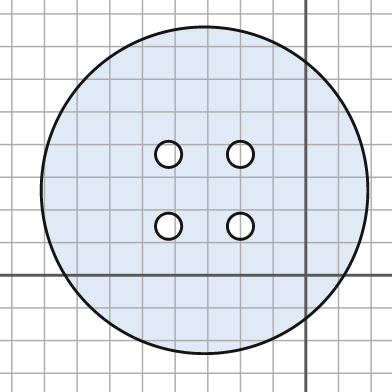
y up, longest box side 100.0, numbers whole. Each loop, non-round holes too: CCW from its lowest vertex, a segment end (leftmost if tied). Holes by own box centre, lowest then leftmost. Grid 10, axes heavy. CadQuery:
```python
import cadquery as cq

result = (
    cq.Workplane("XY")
    .moveTo(-31.0, 26.0)
    .circle(50.0)
    .moveTo(-42.0, 15.0)
    .circle(4.0)
    .moveTo(-20.0, 15.0)
    .circle(4.0)
    .moveTo(-42.0, 37.0)
    .circle(4.0)
    .moveTo(-20.0, 37.0)
    .circle(4.0)
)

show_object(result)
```